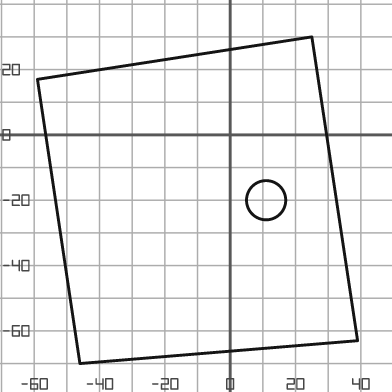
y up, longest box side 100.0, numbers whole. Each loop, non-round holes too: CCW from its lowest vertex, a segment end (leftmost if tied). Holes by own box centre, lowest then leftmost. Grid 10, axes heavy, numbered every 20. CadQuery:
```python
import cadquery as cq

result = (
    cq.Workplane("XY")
    .moveTo(-46.0, -70.0)
    .lineTo(39.0, -63.0)
    .lineTo(25.0, 30.0)
    .lineTo(-59.0, 17.0)
    .close()
    .moveTo(11.0, -20.0)
    .circle(6.0)
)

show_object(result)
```